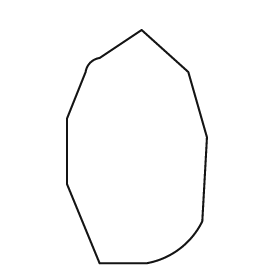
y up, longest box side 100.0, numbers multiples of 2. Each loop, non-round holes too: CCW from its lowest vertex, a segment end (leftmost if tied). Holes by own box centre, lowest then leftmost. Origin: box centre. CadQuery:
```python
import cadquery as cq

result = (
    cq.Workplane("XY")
    .moveTo(-16.0, -50.0)
    .lineTo(4.0, -50.0)
    .threePointArc((18.0, -44.0), (28.0, -32.0))
    .lineTo(30.0, 4.0)
    .lineTo(22.0, 32.0)
    .lineTo(2.0, 50.0)
    .lineTo(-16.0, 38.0)
    .threePointArc((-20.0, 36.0), (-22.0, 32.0))
    .lineTo(-30.0, 12.0)
    .lineTo(-30.0, -16.0)
    .close()
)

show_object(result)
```